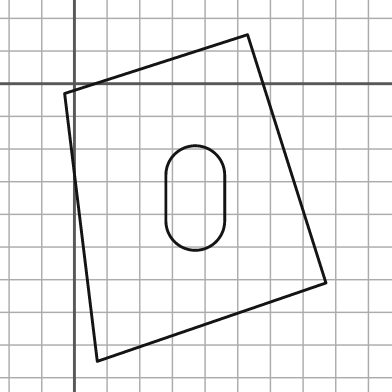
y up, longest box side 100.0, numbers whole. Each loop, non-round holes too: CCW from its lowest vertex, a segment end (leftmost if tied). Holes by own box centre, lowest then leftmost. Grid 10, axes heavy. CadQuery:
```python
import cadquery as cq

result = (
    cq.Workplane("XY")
    .moveTo(7.0, -85.0)
    .lineTo(77.0, -61.0)
    .lineTo(53.0, 15.0)
    .lineTo(-3.0, -3.0)
    .close()
    .moveTo(28.0, -42.0)
    .threePointArc((37.0, -51.0), (46.0, -42.0))
    .lineTo(46.0, -28.0)
    .threePointArc((37.0, -19.0), (28.0, -28.0))
    .close()
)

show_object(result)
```